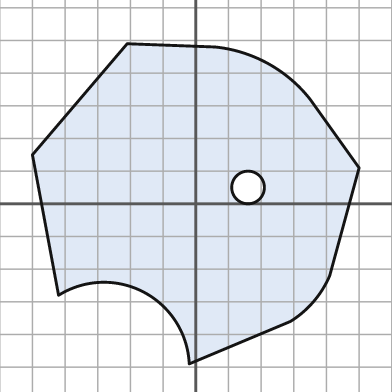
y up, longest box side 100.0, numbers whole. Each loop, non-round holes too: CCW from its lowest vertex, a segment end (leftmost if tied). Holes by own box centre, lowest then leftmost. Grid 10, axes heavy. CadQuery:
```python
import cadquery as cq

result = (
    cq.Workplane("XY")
    .moveTo(-2.0, -49.0)
    .lineTo(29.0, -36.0)
    .threePointArc((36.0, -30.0), (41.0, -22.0))
    .lineTo(50.0, 11.0)
    .lineTo(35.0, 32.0)
    .threePointArc((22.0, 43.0), (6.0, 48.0))
    .lineTo(-21.0, 49.0)
    .lineTo(-50.0, 15.0)
    .lineTo(-42.0, -28.0)
    .threePointArc((-16.0, -27.0), (-2.0, -49.0))
    .close()
    .moveTo(16.0, 5.0)
    .circle(5.0)
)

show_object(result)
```